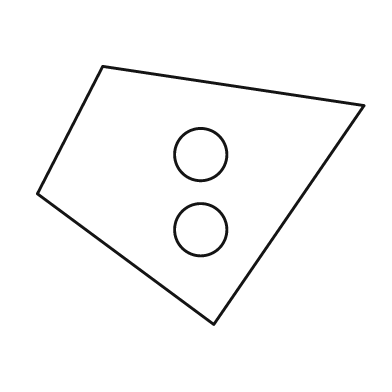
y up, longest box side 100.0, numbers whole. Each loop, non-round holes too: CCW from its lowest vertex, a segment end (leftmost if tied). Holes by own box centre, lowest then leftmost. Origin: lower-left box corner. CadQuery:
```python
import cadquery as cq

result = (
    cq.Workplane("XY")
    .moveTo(54.0, 0.0)
    .lineTo(100.0, 67.0)
    .lineTo(20.0, 79.0)
    .lineTo(0.0, 40.0)
    .close()
    .moveTo(50.0, 29.0)
    .circle(8.0)
    .moveTo(50.0, 52.0)
    .circle(8.0)
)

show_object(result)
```